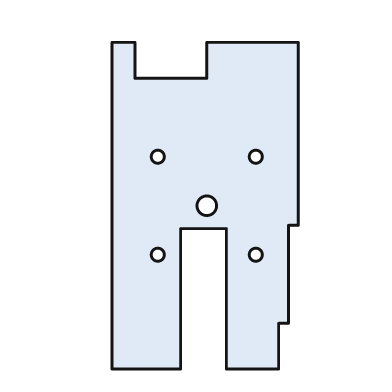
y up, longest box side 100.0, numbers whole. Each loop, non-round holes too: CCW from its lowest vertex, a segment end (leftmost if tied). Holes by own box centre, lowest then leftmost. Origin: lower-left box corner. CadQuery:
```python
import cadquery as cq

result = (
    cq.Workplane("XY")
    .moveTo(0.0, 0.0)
    .lineTo(21.0, 0.0)
    .lineTo(21.0, 43.0)
    .lineTo(35.0, 43.0)
    .lineTo(35.0, 0.0)
    .lineTo(51.0, 0.0)
    .lineTo(51.0, 14.0)
    .lineTo(54.0, 14.0)
    .lineTo(54.0, 44.0)
    .lineTo(57.0, 44.0)
    .lineTo(57.0, 100.0)
    .lineTo(29.0, 100.0)
    .lineTo(29.0, 89.0)
    .lineTo(7.0, 89.0)
    .lineTo(7.0, 100.0)
    .lineTo(0.0, 100.0)
    .close()
    .moveTo(14.0, 35.0)
    .circle(2.0)
    .moveTo(44.0, 35.0)
    .circle(2.0)
    .moveTo(29.0, 50.0)
    .circle(3.0)
    .moveTo(14.0, 65.0)
    .circle(2.0)
    .moveTo(44.0, 65.0)
    .circle(2.0)
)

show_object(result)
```